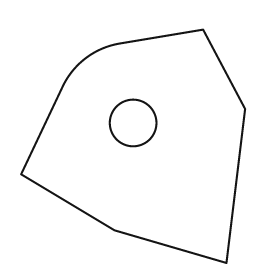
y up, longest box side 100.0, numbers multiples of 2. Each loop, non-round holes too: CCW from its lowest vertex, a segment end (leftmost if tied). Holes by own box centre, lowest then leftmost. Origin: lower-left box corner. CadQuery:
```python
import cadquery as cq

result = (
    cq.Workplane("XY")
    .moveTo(88.0, 0.0)
    .lineTo(96.0, 66.0)
    .lineTo(78.0, 100.0)
    .lineTo(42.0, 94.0)
    .threePointArc((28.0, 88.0), (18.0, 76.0))
    .lineTo(0.0, 38.0)
    .lineTo(40.0, 14.0)
    .close()
    .moveTo(48.0, 60.0)
    .circle(10.0)
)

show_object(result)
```